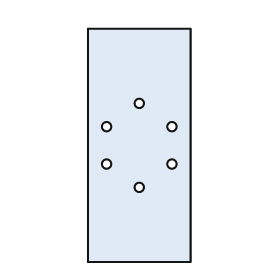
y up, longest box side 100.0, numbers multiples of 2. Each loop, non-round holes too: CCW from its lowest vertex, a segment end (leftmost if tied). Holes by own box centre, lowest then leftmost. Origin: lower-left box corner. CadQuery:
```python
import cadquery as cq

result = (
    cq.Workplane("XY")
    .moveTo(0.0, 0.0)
    .lineTo(44.0, 0.0)
    .lineTo(44.0, 100.0)
    .lineTo(0.0, 100.0)
    .close()
    .moveTo(22.0, 32.0)
    .circle(2.0)
    .moveTo(8.0, 42.0)
    .circle(2.0)
    .moveTo(36.0, 42.0)
    .circle(2.0)
    .moveTo(8.0, 58.0)
    .circle(2.0)
    .moveTo(36.0, 58.0)
    .circle(2.0)
    .moveTo(22.0, 68.0)
    .circle(2.0)
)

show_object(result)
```